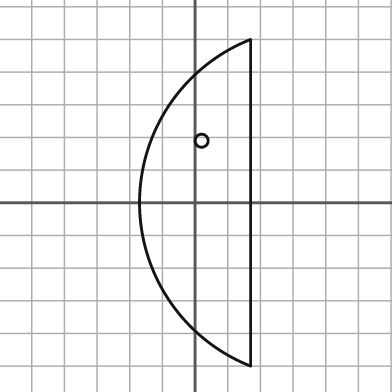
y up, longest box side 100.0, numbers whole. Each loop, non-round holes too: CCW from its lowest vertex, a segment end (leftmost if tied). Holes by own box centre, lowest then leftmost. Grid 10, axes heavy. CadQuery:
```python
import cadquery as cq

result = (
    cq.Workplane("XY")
    .moveTo(17.0, -50.0)
    .lineTo(17.0, 50.0)
    .threePointArc((-17.0, 0.0), (17.0, -50.0))
    .close()
    .moveTo(2.0, 19.0)
    .circle(2.0)
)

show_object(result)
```